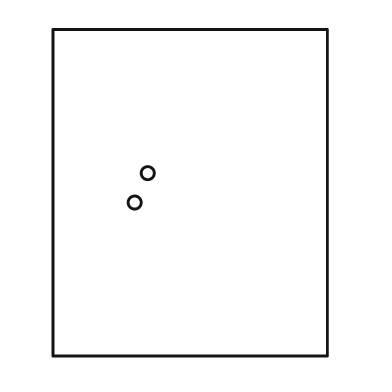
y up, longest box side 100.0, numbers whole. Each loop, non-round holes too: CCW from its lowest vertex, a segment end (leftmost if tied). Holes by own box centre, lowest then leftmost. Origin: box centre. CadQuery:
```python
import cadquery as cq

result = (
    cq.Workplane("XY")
    .moveTo(-42.0, -50.0)
    .lineTo(42.0, -50.0)
    .lineTo(42.0, 50.0)
    .lineTo(-42.0, 50.0)
    .close()
    .moveTo(-17.0, -3.0)
    .circle(2.0)
    .moveTo(-13.0, 6.0)
    .circle(2.0)
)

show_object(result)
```